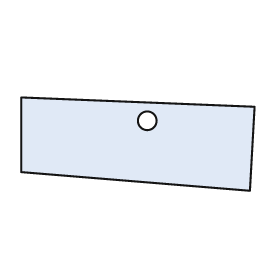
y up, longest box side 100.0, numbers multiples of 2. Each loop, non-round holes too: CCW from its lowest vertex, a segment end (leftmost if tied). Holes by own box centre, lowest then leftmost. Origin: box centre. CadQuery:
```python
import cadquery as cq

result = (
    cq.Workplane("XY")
    .moveTo(48.0, -20.0)
    .lineTo(50.0, 16.0)
    .lineTo(-50.0, 20.0)
    .lineTo(-50.0, -12.0)
    .close()
    .moveTo(4.0, 10.0)
    .circle(4.0)
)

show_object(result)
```